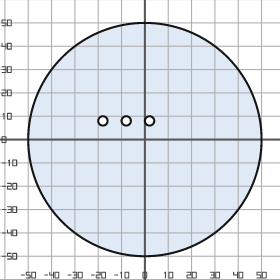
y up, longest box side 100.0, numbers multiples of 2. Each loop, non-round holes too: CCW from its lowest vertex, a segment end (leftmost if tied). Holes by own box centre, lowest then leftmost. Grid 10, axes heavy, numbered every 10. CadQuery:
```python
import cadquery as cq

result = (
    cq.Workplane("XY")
    .moveTo(0.0, 0.0)
    .circle(50.0)
    .moveTo(-18.0, 8.0)
    .circle(2.0)
    .moveTo(-8.0, 8.0)
    .circle(2.0)
    .moveTo(2.0, 8.0)
    .circle(2.0)
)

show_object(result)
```